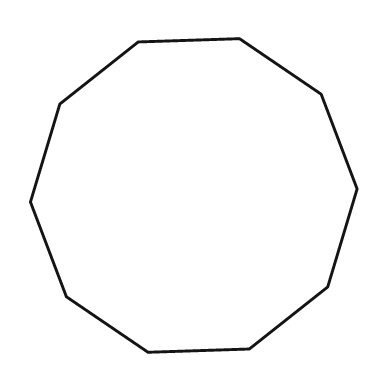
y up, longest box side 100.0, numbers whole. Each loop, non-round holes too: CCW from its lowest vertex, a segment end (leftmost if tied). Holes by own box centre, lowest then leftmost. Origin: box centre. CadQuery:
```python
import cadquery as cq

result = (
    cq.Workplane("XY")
    .moveTo(-14.0, -48.0)
    .lineTo(17.0, -47.0)
    .lineTo(41.0, -28.0)
    .lineTo(50.0, 2.0)
    .lineTo(39.0, 31.0)
    .lineTo(14.0, 48.0)
    .lineTo(-17.0, 47.0)
    .lineTo(-41.0, 28.0)
    .lineTo(-50.0, -2.0)
    .lineTo(-39.0, -31.0)
    .close()
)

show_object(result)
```